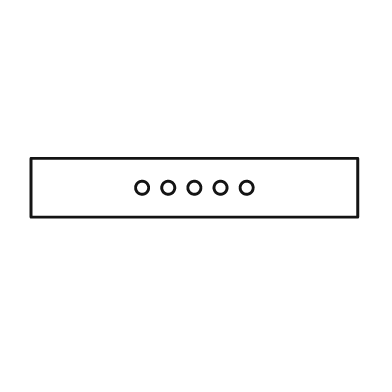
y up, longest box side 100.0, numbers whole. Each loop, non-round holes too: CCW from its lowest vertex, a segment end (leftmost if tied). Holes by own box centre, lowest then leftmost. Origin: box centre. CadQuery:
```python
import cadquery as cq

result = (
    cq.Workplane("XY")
    .moveTo(-50.0, -9.0)
    .lineTo(50.0, -9.0)
    .lineTo(50.0, 9.0)
    .lineTo(-50.0, 9.0)
    .close()
    .moveTo(-16.0, 0.0)
    .circle(2.0)
    .moveTo(-8.0, 0.0)
    .circle(2.0)
    .moveTo(0.0, 0.0)
    .circle(2.0)
    .moveTo(8.0, 0.0)
    .circle(2.0)
    .moveTo(16.0, 0.0)
    .circle(2.0)
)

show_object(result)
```